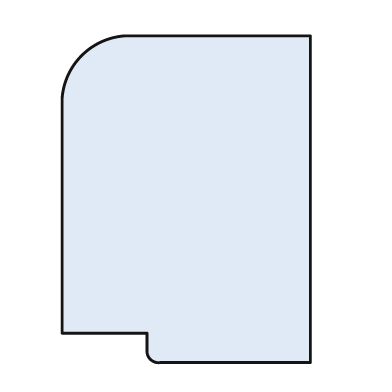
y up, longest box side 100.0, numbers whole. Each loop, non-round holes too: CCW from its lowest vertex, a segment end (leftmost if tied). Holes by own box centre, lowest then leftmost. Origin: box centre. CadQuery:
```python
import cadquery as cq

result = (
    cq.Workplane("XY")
    .moveTo(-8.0, -50.0)
    .lineTo(38.0, -50.0)
    .lineTo(38.0, 50.0)
    .lineTo(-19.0, 50.0)
    .threePointArc((-32.0, 44.0), (-38.0, 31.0))
    .lineTo(-38.0, -41.0)
    .lineTo(-12.0, -41.0)
    .lineTo(-12.0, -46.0)
    .threePointArc((-11.0, -49.0), (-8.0, -50.0))
    .close()
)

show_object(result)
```